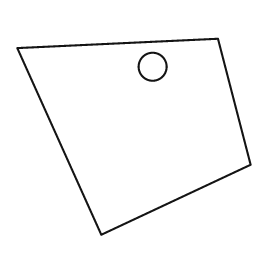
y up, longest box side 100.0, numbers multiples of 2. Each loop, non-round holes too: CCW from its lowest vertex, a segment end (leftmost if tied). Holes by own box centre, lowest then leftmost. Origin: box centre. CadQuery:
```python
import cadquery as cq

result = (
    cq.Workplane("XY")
    .moveTo(-14.0, -42.0)
    .lineTo(50.0, -12.0)
    .lineTo(36.0, 42.0)
    .lineTo(-50.0, 38.0)
    .close()
    .moveTo(8.0, 30.0)
    .circle(6.0)
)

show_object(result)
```